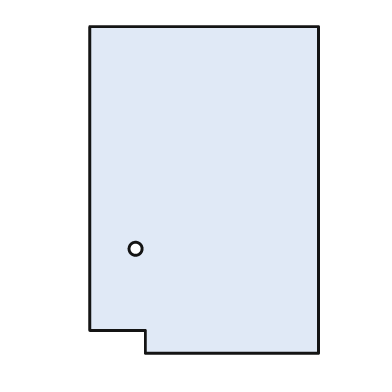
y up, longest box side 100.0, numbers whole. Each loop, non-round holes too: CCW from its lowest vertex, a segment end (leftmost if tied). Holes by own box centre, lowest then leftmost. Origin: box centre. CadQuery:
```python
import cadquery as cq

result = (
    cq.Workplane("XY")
    .moveTo(-18.0, -50.0)
    .lineTo(35.0, -50.0)
    .lineTo(35.0, 50.0)
    .lineTo(-35.0, 50.0)
    .lineTo(-35.0, -43.0)
    .lineTo(-18.0, -43.0)
    .close()
    .moveTo(-21.0, -18.0)
    .circle(2.0)
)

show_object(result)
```